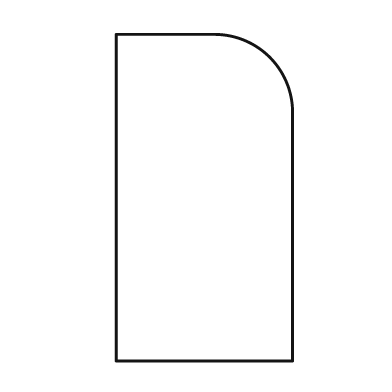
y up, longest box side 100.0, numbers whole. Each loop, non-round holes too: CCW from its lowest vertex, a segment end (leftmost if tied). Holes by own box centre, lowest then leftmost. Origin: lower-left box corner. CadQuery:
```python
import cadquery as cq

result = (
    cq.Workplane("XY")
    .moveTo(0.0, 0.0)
    .lineTo(54.0, 0.0)
    .lineTo(54.0, 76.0)
    .threePointArc((47.0, 93.0), (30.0, 100.0))
    .lineTo(0.0, 100.0)
    .close()
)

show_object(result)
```